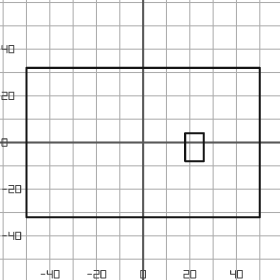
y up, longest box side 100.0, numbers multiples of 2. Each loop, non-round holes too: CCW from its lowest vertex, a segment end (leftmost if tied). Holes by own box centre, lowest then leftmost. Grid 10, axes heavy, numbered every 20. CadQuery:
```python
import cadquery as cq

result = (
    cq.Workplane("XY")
    .moveTo(-50.0, -32.0)
    .lineTo(50.0, -32.0)
    .lineTo(50.0, 32.0)
    .lineTo(-50.0, 32.0)
    .close()
    .moveTo(18.0, -8.0)
    .lineTo(26.0, -8.0)
    .lineTo(26.0, 4.0)
    .lineTo(18.0, 4.0)
    .close()
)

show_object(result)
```